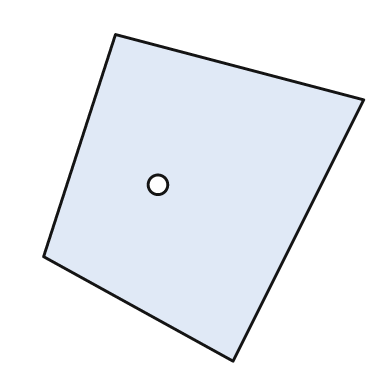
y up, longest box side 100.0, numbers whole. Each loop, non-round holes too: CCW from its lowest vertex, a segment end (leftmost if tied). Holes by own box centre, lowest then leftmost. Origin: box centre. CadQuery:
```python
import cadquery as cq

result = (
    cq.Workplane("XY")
    .moveTo(9.0, -50.0)
    .lineTo(49.0, 30.0)
    .lineTo(-27.0, 50.0)
    .lineTo(-49.0, -18.0)
    .close()
    .moveTo(-14.0, 4.0)
    .circle(3.0)
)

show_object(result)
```